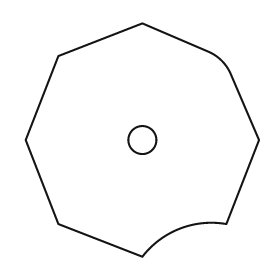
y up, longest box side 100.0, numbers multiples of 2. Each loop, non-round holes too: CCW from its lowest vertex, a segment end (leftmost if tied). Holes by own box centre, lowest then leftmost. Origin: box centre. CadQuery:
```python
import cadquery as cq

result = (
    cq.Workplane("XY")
    .moveTo(0.0, -50.0)
    .threePointArc((16.0, -38.0), (36.0, -36.0))
    .lineTo(50.0, 0.0)
    .lineTo(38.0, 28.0)
    .threePointArc((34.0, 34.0), (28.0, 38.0))
    .lineTo(0.0, 50.0)
    .lineTo(-36.0, 36.0)
    .lineTo(-50.0, 0.0)
    .lineTo(-36.0, -36.0)
    .close()
    .moveTo(0.0, 0.0)
    .circle(6.0)
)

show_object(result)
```